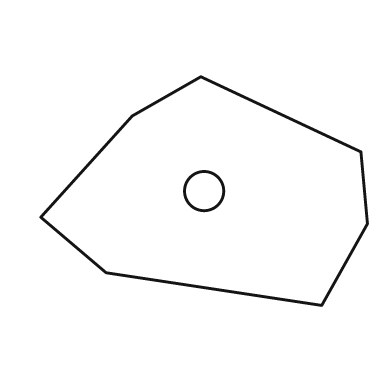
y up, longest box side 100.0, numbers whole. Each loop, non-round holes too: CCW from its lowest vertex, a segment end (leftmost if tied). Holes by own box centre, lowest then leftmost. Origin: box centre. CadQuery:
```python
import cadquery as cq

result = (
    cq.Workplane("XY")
    .moveTo(36.0, -35.0)
    .lineTo(50.0, -10.0)
    .lineTo(48.0, 12.0)
    .lineTo(-1.0, 35.0)
    .lineTo(-22.0, 23.0)
    .lineTo(-50.0, -8.0)
    .lineTo(-30.0, -25.0)
    .close()
    .moveTo(0.0, 0.0)
    .circle(6.0)
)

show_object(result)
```